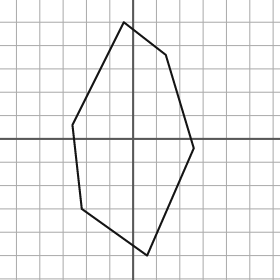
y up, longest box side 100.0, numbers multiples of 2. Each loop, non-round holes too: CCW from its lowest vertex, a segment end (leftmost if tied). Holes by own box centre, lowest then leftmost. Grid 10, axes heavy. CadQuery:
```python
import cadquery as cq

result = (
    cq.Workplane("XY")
    .moveTo(6.0, -50.0)
    .lineTo(26.0, -4.0)
    .lineTo(14.0, 36.0)
    .lineTo(-4.0, 50.0)
    .lineTo(-26.0, 6.0)
    .lineTo(-22.0, -30.0)
    .close()
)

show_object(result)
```